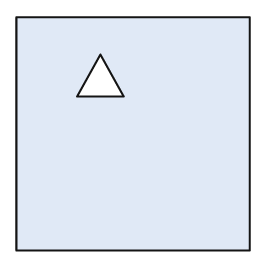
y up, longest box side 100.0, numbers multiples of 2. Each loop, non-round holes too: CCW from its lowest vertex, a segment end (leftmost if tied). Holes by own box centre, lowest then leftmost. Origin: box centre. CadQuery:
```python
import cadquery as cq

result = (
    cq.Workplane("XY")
    .moveTo(-50.0, -50.0)
    .lineTo(50.0, -50.0)
    .lineTo(50.0, 50.0)
    .lineTo(-50.0, 50.0)
    .close()
    .moveTo(-24.0, 16.0)
    .lineTo(-4.0, 16.0)
    .lineTo(-14.0, 34.0)
    .close()
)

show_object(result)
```